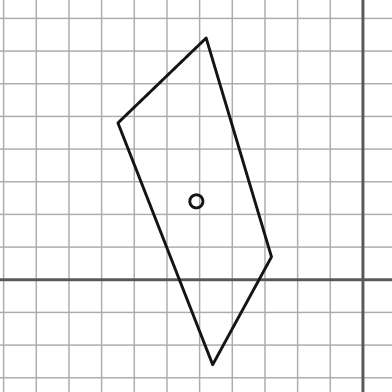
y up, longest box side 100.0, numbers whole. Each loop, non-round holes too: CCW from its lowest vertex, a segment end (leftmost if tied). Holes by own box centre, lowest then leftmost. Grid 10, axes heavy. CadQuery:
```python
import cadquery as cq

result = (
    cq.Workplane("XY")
    .moveTo(-46.0, -26.0)
    .lineTo(-28.0, 7.0)
    .lineTo(-48.0, 74.0)
    .lineTo(-75.0, 48.0)
    .close()
    .moveTo(-51.0, 24.0)
    .circle(2.0)
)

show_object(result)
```